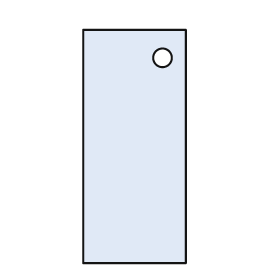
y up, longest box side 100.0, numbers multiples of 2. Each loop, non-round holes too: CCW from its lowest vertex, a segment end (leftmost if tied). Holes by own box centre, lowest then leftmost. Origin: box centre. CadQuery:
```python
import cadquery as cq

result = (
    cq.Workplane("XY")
    .moveTo(-22.0, -50.0)
    .lineTo(22.0, -50.0)
    .lineTo(22.0, 50.0)
    .lineTo(-22.0, 50.0)
    .close()
    .moveTo(12.0, 38.0)
    .circle(4.0)
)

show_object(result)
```